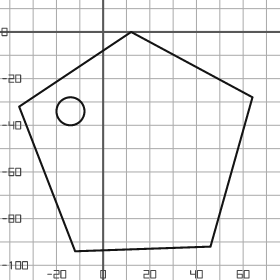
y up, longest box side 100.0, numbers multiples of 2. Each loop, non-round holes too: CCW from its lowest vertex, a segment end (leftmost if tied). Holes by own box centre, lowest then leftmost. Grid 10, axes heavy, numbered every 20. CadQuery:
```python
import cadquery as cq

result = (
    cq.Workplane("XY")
    .moveTo(-12.0, -94.0)
    .lineTo(46.0, -92.0)
    .lineTo(64.0, -28.0)
    .lineTo(12.0, 0.0)
    .lineTo(-36.0, -32.0)
    .close()
    .moveTo(-14.0, -34.0)
    .circle(6.0)
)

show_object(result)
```